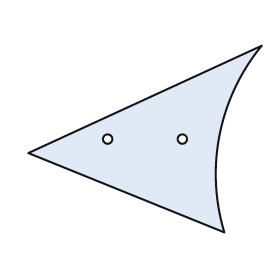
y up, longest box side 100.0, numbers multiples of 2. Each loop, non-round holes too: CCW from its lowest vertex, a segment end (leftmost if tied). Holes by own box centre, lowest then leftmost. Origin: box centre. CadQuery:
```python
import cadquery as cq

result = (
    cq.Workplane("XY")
    .moveTo(34.0, -40.0)
    .threePointArc((32.0, 2.0), (50.0, 40.0))
    .lineTo(-50.0, -6.0)
    .close()
    .moveTo(-16.0, 0.0)
    .circle(2.0)
    .moveTo(16.0, 0.0)
    .circle(2.0)
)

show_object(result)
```